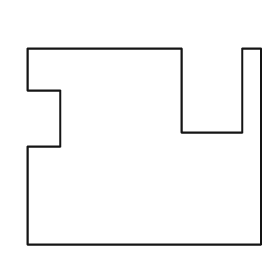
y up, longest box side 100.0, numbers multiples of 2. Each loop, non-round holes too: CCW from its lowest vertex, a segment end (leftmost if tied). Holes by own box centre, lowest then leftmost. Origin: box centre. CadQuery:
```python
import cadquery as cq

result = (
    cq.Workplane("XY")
    .moveTo(-50.0, -42.0)
    .lineTo(50.0, -42.0)
    .lineTo(50.0, 42.0)
    .lineTo(42.0, 42.0)
    .lineTo(42.0, 6.0)
    .lineTo(16.0, 6.0)
    .lineTo(16.0, 42.0)
    .lineTo(-50.0, 42.0)
    .lineTo(-50.0, 24.0)
    .lineTo(-36.0, 24.0)
    .lineTo(-36.0, 0.0)
    .lineTo(-50.0, 0.0)
    .close()
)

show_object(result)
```